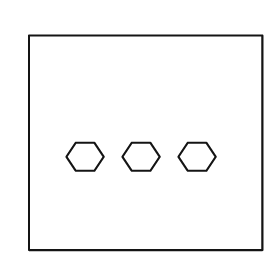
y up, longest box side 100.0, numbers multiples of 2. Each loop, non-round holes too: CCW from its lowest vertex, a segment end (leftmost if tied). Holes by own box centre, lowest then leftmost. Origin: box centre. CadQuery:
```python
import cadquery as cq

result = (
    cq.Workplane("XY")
    .moveTo(-50.0, -46.0)
    .lineTo(50.0, -46.0)
    .lineTo(50.0, 46.0)
    .lineTo(-50.0, 46.0)
    .close()
    .moveTo(-30.0, -12.0)
    .lineTo(-22.0, -12.0)
    .lineTo(-18.0, -6.0)
    .lineTo(-22.0, 0.0)
    .lineTo(-30.0, 0.0)
    .lineTo(-34.0, -6.0)
    .close()
    .moveTo(-6.0, -12.0)
    .lineTo(2.0, -12.0)
    .lineTo(6.0, -6.0)
    .lineTo(2.0, 0.0)
    .lineTo(-6.0, 0.0)
    .lineTo(-10.0, -6.0)
    .close()
    .moveTo(18.0, -12.0)
    .lineTo(26.0, -12.0)
    .lineTo(30.0, -6.0)
    .lineTo(26.0, 0.0)
    .lineTo(18.0, 0.0)
    .lineTo(14.0, -6.0)
    .close()
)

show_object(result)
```